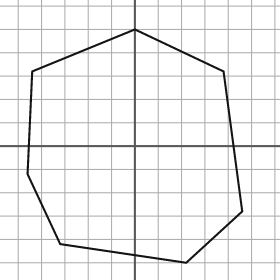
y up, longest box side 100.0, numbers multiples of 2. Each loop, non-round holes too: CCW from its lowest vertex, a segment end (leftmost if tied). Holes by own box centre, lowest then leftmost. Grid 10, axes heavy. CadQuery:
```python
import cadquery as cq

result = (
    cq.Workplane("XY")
    .moveTo(22.0, -50.0)
    .lineTo(46.0, -28.0)
    .lineTo(38.0, 32.0)
    .lineTo(0.0, 50.0)
    .lineTo(-44.0, 32.0)
    .lineTo(-46.0, -12.0)
    .lineTo(-32.0, -42.0)
    .close()
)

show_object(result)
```